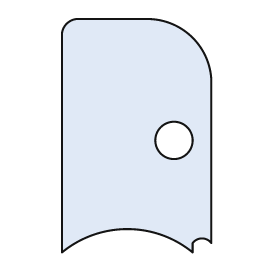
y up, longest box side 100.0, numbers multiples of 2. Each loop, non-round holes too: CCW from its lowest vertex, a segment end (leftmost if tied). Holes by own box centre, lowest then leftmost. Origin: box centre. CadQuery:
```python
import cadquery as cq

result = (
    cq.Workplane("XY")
    .moveTo(-32.0, -50.0)
    .threePointArc((-4.0, -40.0), (24.0, -50.0))
    .lineTo(24.0, -46.0)
    .threePointArc((28.0, -44.0), (32.0, -46.0))
    .lineTo(32.0, 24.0)
    .threePointArc((24.0, 42.0), (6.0, 50.0))
    .lineTo(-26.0, 50.0)
    .threePointArc((-30.0, 48.0), (-32.0, 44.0))
    .close()
    .moveTo(16.0, -2.0)
    .circle(8.0)
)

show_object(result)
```